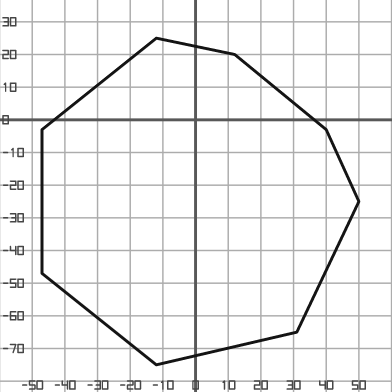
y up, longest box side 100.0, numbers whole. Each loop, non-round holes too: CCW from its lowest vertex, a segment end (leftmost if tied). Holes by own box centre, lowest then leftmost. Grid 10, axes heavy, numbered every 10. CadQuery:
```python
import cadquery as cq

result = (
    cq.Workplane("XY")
    .moveTo(-12.0, -75.0)
    .lineTo(31.0, -65.0)
    .lineTo(50.0, -25.0)
    .lineTo(40.0, -3.0)
    .lineTo(12.0, 20.0)
    .lineTo(-12.0, 25.0)
    .lineTo(-47.0, -3.0)
    .lineTo(-47.0, -47.0)
    .close()
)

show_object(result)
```